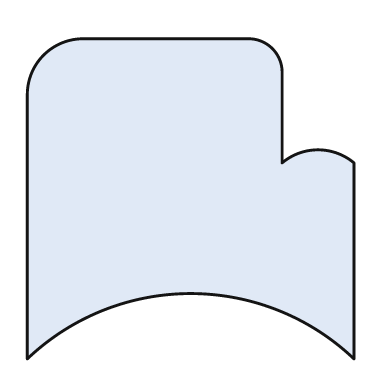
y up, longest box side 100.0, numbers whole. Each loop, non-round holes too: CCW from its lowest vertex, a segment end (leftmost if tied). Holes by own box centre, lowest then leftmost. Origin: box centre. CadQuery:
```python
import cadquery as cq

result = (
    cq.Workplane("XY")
    .moveTo(-50.0, -49.0)
    .threePointArc((0.0, -29.0), (50.0, -49.0))
    .lineTo(50.0, 11.0)
    .threePointArc((39.0, 15.0), (28.0, 11.0))
    .lineTo(28.0, 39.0)
    .threePointArc((25.0, 46.0), (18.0, 49.0))
    .lineTo(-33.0, 49.0)
    .threePointArc((-45.0, 44.0), (-50.0, 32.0))
    .close()
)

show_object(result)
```